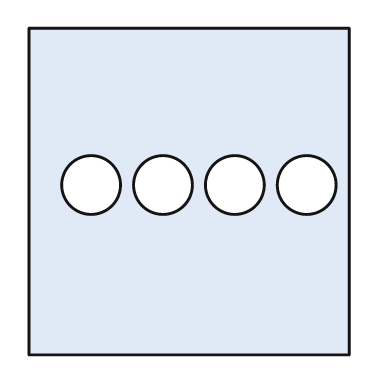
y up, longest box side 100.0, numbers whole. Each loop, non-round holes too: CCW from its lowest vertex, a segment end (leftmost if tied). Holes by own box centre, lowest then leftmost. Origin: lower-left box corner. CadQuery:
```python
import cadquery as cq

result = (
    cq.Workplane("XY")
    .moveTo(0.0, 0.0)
    .lineTo(98.0, 0.0)
    .lineTo(98.0, 100.0)
    .lineTo(0.0, 100.0)
    .close()
    .moveTo(19.0, 52.0)
    .circle(9.0)
    .moveTo(41.0, 52.0)
    .circle(9.0)
    .moveTo(63.0, 52.0)
    .circle(9.0)
    .moveTo(85.0, 52.0)
    .circle(9.0)
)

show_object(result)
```